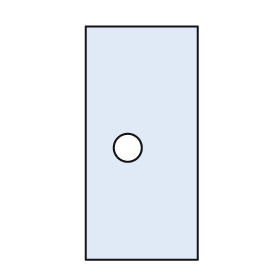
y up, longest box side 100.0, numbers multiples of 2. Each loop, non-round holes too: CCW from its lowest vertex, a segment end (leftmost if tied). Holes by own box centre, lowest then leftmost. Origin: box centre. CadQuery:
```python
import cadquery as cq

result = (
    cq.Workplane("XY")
    .moveTo(-24.0, -50.0)
    .lineTo(24.0, -50.0)
    .lineTo(24.0, 50.0)
    .lineTo(-24.0, 50.0)
    .close()
    .moveTo(-6.0, -2.0)
    .circle(6.0)
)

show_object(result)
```